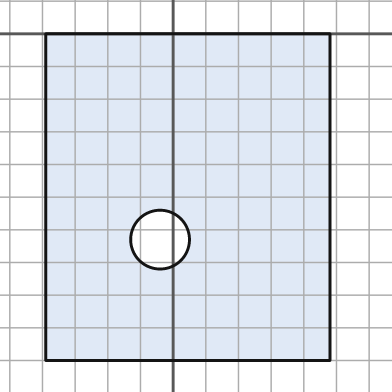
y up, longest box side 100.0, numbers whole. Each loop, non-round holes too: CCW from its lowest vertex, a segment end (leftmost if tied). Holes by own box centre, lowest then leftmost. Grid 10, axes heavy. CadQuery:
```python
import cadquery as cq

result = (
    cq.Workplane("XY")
    .moveTo(-39.0, -100.0)
    .lineTo(48.0, -100.0)
    .lineTo(48.0, 0.0)
    .lineTo(-39.0, 0.0)
    .close()
    .moveTo(-4.0, -63.0)
    .circle(9.0)
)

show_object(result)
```